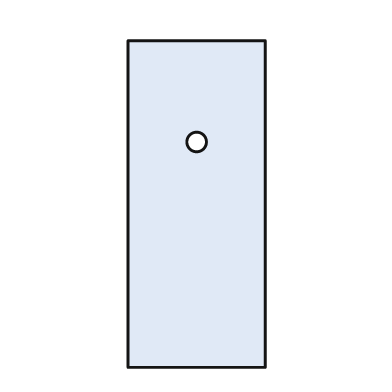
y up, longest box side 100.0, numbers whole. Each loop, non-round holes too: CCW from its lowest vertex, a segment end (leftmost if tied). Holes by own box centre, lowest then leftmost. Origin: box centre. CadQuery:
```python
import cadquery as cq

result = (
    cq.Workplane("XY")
    .moveTo(-21.0, -50.0)
    .lineTo(21.0, -50.0)
    .lineTo(21.0, 50.0)
    .lineTo(-21.0, 50.0)
    .close()
    .moveTo(0.0, 19.0)
    .circle(3.0)
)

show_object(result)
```